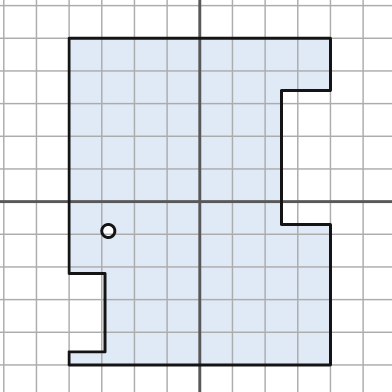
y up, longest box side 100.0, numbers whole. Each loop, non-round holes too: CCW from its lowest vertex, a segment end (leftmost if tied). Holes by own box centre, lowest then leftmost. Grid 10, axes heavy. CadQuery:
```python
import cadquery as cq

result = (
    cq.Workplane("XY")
    .moveTo(-40.0, -50.0)
    .lineTo(40.0, -50.0)
    .lineTo(40.0, -7.0)
    .lineTo(25.0, -7.0)
    .lineTo(25.0, 34.0)
    .lineTo(40.0, 34.0)
    .lineTo(40.0, 50.0)
    .lineTo(-40.0, 50.0)
    .lineTo(-40.0, -22.0)
    .lineTo(-29.0, -22.0)
    .lineTo(-29.0, -46.0)
    .lineTo(-40.0, -46.0)
    .close()
    .moveTo(-28.0, -9.0)
    .circle(2.0)
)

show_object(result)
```